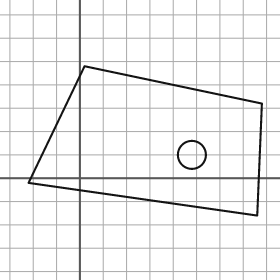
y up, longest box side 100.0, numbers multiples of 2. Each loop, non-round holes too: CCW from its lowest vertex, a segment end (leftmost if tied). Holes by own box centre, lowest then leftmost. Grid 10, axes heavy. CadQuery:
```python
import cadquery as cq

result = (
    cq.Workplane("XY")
    .moveTo(76.0, -16.0)
    .lineTo(78.0, 32.0)
    .lineTo(2.0, 48.0)
    .lineTo(-22.0, -2.0)
    .close()
    .moveTo(48.0, 10.0)
    .circle(6.0)
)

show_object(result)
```